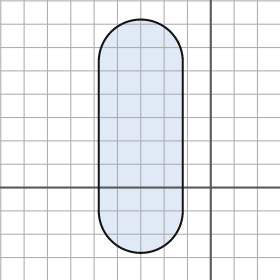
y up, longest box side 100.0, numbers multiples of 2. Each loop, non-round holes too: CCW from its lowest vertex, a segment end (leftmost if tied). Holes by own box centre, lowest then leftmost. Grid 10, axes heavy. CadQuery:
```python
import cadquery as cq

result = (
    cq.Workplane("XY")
    .moveTo(-48.0, -10.0)
    .threePointArc((-30.0, -28.0), (-12.0, -10.0))
    .lineTo(-12.0, 54.0)
    .threePointArc((-30.0, 72.0), (-48.0, 54.0))
    .close()
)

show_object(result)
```